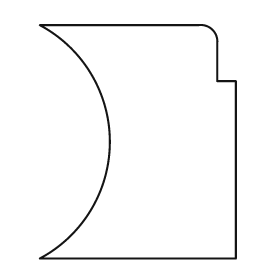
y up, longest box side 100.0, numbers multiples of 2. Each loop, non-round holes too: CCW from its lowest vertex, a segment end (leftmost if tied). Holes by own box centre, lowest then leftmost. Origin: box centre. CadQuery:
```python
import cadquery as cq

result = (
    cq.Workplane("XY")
    .moveTo(-42.0, -50.0)
    .lineTo(42.0, -50.0)
    .lineTo(42.0, 26.0)
    .lineTo(34.0, 26.0)
    .lineTo(34.0, 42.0)
    .threePointArc((32.0, 48.0), (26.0, 50.0))
    .lineTo(-42.0, 50.0)
    .threePointArc((-12.0, 0.0), (-42.0, -50.0))
    .close()
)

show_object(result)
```